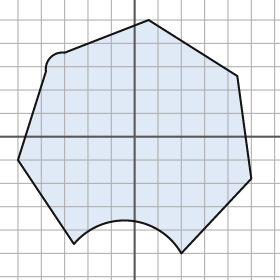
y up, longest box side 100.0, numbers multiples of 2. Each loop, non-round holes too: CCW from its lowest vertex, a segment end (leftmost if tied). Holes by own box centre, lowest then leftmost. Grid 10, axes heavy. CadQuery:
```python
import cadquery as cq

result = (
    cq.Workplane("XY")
    .moveTo(20.0, -50.0)
    .lineTo(50.0, -18.0)
    .lineTo(44.0, 26.0)
    .lineTo(6.0, 50.0)
    .lineTo(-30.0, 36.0)
    .threePointArc((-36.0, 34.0), (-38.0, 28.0))
    .lineTo(-50.0, -10.0)
    .lineTo(-26.0, -46.0)
    .threePointArc((-2.0, -36.0), (20.0, -50.0))
    .close()
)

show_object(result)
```